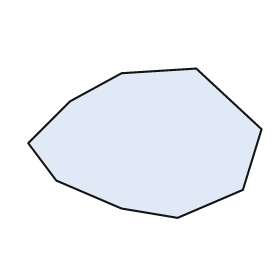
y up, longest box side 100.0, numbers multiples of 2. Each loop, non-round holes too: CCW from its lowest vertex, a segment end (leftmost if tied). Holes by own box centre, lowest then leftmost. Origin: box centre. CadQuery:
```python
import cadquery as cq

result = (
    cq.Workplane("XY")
    .moveTo(14.0, -32.0)
    .lineTo(42.0, -20.0)
    .lineTo(50.0, 6.0)
    .lineTo(22.0, 32.0)
    .lineTo(-10.0, 30.0)
    .lineTo(-32.0, 18.0)
    .lineTo(-50.0, 0.0)
    .lineTo(-38.0, -16.0)
    .lineTo(-10.0, -28.0)
    .close()
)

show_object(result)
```